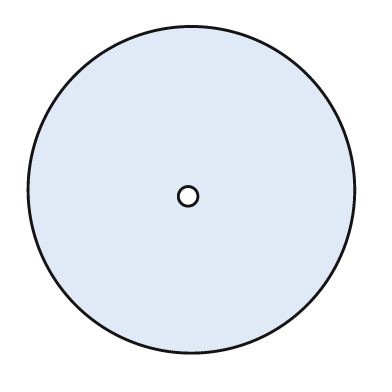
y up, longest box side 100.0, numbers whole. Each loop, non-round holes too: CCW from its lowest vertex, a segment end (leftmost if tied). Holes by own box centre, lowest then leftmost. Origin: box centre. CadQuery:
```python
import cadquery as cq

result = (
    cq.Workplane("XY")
    .moveTo(0.0, 0.0)
    .circle(50.0)
    .moveTo(-1.0, -2.0)
    .circle(3.0)
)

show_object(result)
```